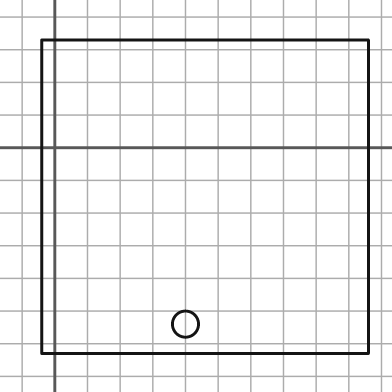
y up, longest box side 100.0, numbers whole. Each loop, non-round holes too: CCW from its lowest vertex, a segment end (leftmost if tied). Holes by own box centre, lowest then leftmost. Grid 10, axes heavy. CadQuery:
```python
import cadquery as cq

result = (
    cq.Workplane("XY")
    .moveTo(-4.0, -63.0)
    .lineTo(96.0, -63.0)
    .lineTo(96.0, 33.0)
    .lineTo(-4.0, 33.0)
    .close()
    .moveTo(40.0, -54.0)
    .circle(4.0)
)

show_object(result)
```